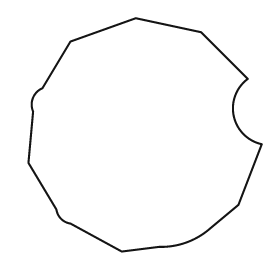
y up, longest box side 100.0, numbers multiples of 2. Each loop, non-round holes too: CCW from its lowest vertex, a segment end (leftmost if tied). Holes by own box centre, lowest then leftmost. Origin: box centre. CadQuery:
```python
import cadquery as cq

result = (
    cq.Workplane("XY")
    .moveTo(-10.0, -50.0)
    .lineTo(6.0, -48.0)
    .threePointArc((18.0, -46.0), (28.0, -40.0))
    .lineTo(40.0, -30.0)
    .lineTo(50.0, -4.0)
    .threePointArc((38.0, 8.0), (44.0, 24.0))
    .lineTo(24.0, 44.0)
    .lineTo(-4.0, 50.0)
    .lineTo(-32.0, 40.0)
    .lineTo(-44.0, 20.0)
    .threePointArc((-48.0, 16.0), (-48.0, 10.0))
    .lineTo(-50.0, -12.0)
    .lineTo(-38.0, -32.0)
    .threePointArc((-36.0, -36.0), (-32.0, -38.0))
    .close()
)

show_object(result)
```